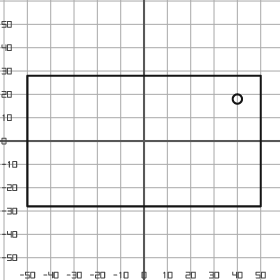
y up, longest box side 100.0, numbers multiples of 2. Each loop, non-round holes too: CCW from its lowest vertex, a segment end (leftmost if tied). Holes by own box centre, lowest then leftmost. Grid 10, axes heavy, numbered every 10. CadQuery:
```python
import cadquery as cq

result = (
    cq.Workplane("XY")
    .moveTo(-50.0, -28.0)
    .lineTo(50.0, -28.0)
    .lineTo(50.0, 28.0)
    .lineTo(-50.0, 28.0)
    .close()
    .moveTo(40.0, 18.0)
    .circle(2.0)
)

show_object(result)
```